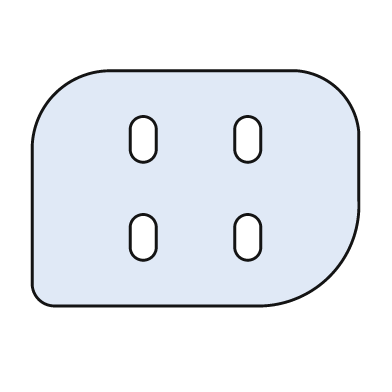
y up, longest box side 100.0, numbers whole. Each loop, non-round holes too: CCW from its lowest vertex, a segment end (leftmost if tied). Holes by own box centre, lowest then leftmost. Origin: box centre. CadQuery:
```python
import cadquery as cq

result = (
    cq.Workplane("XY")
    .moveTo(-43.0, -36.0)
    .lineTo(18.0, -36.0)
    .threePointArc((41.0, -27.0), (50.0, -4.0))
    .lineTo(50.0, 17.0)
    .threePointArc((44.0, 30.0), (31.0, 36.0))
    .lineTo(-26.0, 36.0)
    .threePointArc((-43.0, 29.0), (-50.0, 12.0))
    .lineTo(-50.0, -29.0)
    .threePointArc((-48.0, -34.0), (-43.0, -36.0))
    .close()
    .moveTo(-20.0, -18.0)
    .threePointArc((-16.0, -22.0), (-12.0, -18.0))
    .lineTo(-12.0, -12.0)
    .threePointArc((-16.0, -8.0), (-20.0, -12.0))
    .close()
    .moveTo(12.0, -18.0)
    .threePointArc((16.0, -22.0), (20.0, -18.0))
    .lineTo(20.0, -12.0)
    .threePointArc((16.0, -8.0), (12.0, -12.0))
    .close()
    .moveTo(-20.0, 12.0)
    .threePointArc((-16.0, 8.0), (-12.0, 12.0))
    .lineTo(-12.0, 18.0)
    .threePointArc((-16.0, 22.0), (-20.0, 18.0))
    .close()
    .moveTo(12.0, 12.0)
    .threePointArc((16.0, 8.0), (20.0, 12.0))
    .lineTo(20.0, 18.0)
    .threePointArc((16.0, 22.0), (12.0, 18.0))
    .close()
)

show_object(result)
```